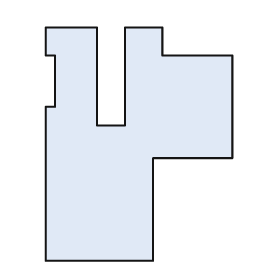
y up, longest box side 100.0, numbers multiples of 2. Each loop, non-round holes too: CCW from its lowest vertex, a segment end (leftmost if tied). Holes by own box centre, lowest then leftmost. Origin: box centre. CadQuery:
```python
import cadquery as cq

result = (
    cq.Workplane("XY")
    .moveTo(-40.0, -50.0)
    .lineTo(6.0, -50.0)
    .lineTo(6.0, -6.0)
    .lineTo(40.0, -6.0)
    .lineTo(40.0, 38.0)
    .lineTo(10.0, 38.0)
    .lineTo(10.0, 50.0)
    .lineTo(-6.0, 50.0)
    .lineTo(-6.0, 8.0)
    .lineTo(-18.0, 8.0)
    .lineTo(-18.0, 50.0)
    .lineTo(-40.0, 50.0)
    .lineTo(-40.0, 38.0)
    .lineTo(-36.0, 38.0)
    .lineTo(-36.0, 16.0)
    .lineTo(-40.0, 16.0)
    .close()
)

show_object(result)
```